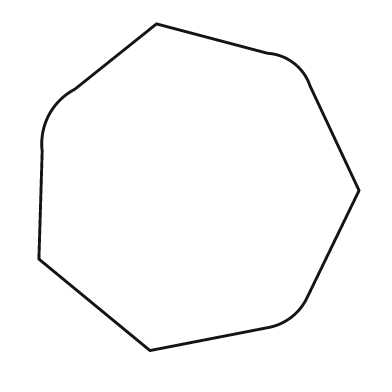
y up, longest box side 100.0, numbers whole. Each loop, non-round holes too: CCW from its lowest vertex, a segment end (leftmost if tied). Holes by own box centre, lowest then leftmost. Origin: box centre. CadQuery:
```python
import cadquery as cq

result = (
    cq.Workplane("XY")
    .moveTo(-15.0, -50.0)
    .lineTo(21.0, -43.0)
    .threePointArc((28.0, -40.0), (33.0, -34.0))
    .lineTo(49.0, -1.0)
    .lineTo(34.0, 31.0)
    .threePointArc((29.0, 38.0), (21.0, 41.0))
    .lineTo(-13.0, 50.0)
    .lineTo(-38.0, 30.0)
    .threePointArc((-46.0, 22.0), (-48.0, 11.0))
    .lineTo(-49.0, -22.0)
    .close()
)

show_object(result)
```